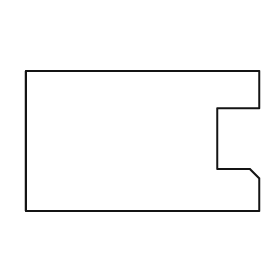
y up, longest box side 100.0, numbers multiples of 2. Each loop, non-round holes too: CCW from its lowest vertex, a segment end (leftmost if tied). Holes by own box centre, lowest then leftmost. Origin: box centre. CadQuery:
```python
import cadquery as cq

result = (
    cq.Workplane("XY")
    .moveTo(-50.0, -30.0)
    .lineTo(50.0, -30.0)
    .lineTo(50.0, -16.0)
    .lineTo(46.0, -12.0)
    .lineTo(32.0, -12.0)
    .lineTo(32.0, 14.0)
    .lineTo(50.0, 14.0)
    .lineTo(50.0, 30.0)
    .lineTo(-50.0, 30.0)
    .close()
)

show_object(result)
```